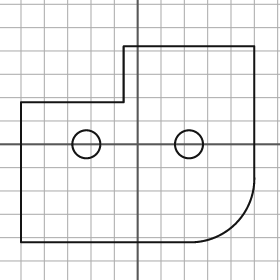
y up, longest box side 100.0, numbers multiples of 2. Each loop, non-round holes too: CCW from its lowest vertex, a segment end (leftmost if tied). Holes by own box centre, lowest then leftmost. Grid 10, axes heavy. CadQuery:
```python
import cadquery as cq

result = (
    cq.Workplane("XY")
    .moveTo(-50.0, -42.0)
    .lineTo(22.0, -42.0)
    .threePointArc((42.0, -34.0), (50.0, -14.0))
    .lineTo(50.0, 42.0)
    .lineTo(-6.0, 42.0)
    .lineTo(-6.0, 18.0)
    .lineTo(-50.0, 18.0)
    .close()
    .moveTo(-22.0, 0.0)
    .circle(6.0)
    .moveTo(22.0, 0.0)
    .circle(6.0)
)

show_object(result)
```